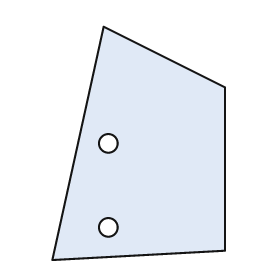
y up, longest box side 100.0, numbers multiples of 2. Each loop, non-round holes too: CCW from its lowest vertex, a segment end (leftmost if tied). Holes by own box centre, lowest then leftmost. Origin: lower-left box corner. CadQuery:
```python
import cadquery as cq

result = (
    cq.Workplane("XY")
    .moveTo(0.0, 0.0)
    .lineTo(74.0, 4.0)
    .lineTo(74.0, 74.0)
    .lineTo(22.0, 100.0)
    .close()
    .moveTo(24.0, 14.0)
    .circle(4.0)
    .moveTo(24.0, 50.0)
    .circle(4.0)
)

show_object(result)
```